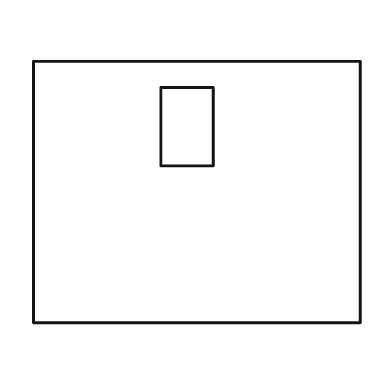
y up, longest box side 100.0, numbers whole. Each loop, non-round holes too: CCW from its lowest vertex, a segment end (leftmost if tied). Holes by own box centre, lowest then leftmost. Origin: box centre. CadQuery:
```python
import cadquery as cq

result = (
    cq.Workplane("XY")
    .moveTo(-50.0, -40.0)
    .lineTo(50.0, -40.0)
    .lineTo(50.0, 40.0)
    .lineTo(-50.0, 40.0)
    .close()
    .moveTo(-11.0, 8.0)
    .lineTo(5.0, 8.0)
    .lineTo(5.0, 32.0)
    .lineTo(-11.0, 32.0)
    .close()
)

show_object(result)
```